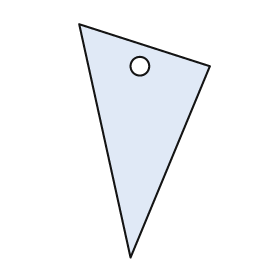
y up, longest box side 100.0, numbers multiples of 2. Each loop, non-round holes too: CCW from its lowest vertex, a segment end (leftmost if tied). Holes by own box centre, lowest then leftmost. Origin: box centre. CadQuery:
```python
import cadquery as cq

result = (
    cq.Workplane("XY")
    .moveTo(-6.0, -50.0)
    .lineTo(28.0, 32.0)
    .lineTo(-28.0, 50.0)
    .close()
    .moveTo(-2.0, 32.0)
    .circle(4.0)
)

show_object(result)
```